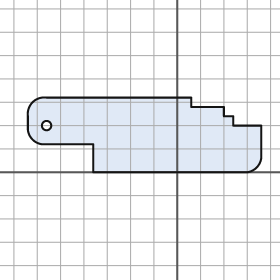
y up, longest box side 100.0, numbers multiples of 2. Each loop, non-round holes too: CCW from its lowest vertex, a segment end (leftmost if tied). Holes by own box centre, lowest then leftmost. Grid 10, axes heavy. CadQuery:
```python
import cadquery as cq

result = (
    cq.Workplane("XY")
    .moveTo(-36.0, 0.0)
    .lineTo(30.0, 0.0)
    .threePointArc((34.0, 2.0), (36.0, 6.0))
    .lineTo(36.0, 20.0)
    .lineTo(24.0, 20.0)
    .lineTo(24.0, 24.0)
    .lineTo(20.0, 24.0)
    .lineTo(20.0, 28.0)
    .lineTo(6.0, 28.0)
    .lineTo(6.0, 32.0)
    .lineTo(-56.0, 32.0)
    .threePointArc((-62.0, 30.0), (-64.0, 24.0))
    .lineTo(-64.0, 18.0)
    .threePointArc((-62.0, 14.0), (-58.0, 12.0))
    .lineTo(-36.0, 12.0)
    .close()
    .moveTo(-56.0, 20.0)
    .circle(2.0)
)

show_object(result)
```